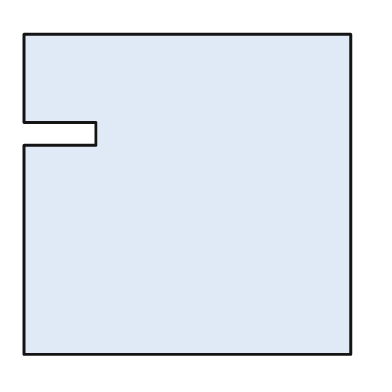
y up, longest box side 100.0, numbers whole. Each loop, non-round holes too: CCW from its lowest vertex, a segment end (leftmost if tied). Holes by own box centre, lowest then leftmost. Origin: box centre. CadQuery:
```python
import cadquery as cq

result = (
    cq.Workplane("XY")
    .moveTo(-50.0, -49.0)
    .lineTo(50.0, -49.0)
    .lineTo(50.0, 49.0)
    .lineTo(-50.0, 49.0)
    .lineTo(-50.0, 22.0)
    .lineTo(-28.0, 22.0)
    .lineTo(-28.0, 15.0)
    .lineTo(-50.0, 15.0)
    .close()
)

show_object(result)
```